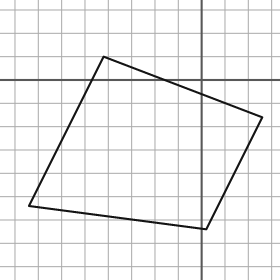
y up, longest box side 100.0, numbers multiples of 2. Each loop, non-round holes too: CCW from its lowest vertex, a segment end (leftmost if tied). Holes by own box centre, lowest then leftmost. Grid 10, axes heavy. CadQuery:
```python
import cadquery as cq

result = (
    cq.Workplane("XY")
    .moveTo(2.0, -64.0)
    .lineTo(26.0, -16.0)
    .lineTo(-42.0, 10.0)
    .lineTo(-74.0, -54.0)
    .close()
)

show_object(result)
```